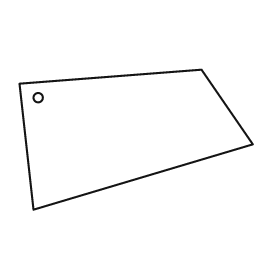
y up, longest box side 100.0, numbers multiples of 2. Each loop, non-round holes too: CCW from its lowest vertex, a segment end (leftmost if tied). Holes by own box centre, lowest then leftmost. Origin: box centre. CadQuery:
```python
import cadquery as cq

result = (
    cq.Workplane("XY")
    .moveTo(-44.0, -30.0)
    .lineTo(50.0, -2.0)
    .lineTo(28.0, 30.0)
    .lineTo(-50.0, 24.0)
    .close()
    .moveTo(-42.0, 18.0)
    .circle(2.0)
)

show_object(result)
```